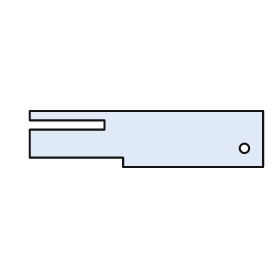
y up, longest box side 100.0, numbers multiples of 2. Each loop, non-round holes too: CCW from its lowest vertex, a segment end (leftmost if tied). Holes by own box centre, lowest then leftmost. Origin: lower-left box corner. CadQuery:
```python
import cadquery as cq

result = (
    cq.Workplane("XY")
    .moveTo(40.0, 0.0)
    .lineTo(100.0, 0.0)
    .lineTo(100.0, 24.0)
    .lineTo(0.0, 24.0)
    .lineTo(0.0, 20.0)
    .lineTo(32.0, 20.0)
    .lineTo(32.0, 16.0)
    .lineTo(0.0, 16.0)
    .lineTo(0.0, 4.0)
    .lineTo(40.0, 4.0)
    .close()
    .moveTo(92.0, 8.0)
    .circle(2.0)
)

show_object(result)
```